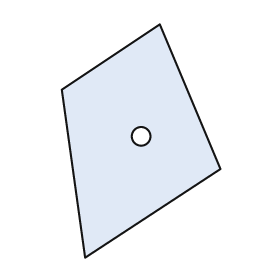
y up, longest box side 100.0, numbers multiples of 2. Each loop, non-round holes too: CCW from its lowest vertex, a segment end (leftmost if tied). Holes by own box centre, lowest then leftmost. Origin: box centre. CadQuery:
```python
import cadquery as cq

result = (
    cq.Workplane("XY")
    .moveTo(-24.0, -50.0)
    .lineTo(34.0, -12.0)
    .lineTo(8.0, 50.0)
    .lineTo(-34.0, 22.0)
    .close()
    .moveTo(0.0, 2.0)
    .circle(4.0)
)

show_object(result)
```